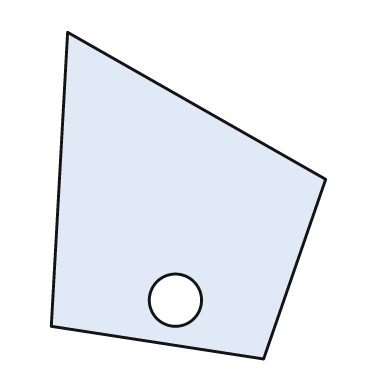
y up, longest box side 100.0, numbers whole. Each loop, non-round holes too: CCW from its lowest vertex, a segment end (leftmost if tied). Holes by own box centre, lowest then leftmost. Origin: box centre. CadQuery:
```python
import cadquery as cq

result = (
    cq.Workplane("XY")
    .moveTo(23.0, -50.0)
    .lineTo(42.0, 5.0)
    .lineTo(-37.0, 50.0)
    .lineTo(-42.0, -40.0)
    .close()
    .moveTo(-4.0, -32.0)
    .circle(8.0)
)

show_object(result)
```